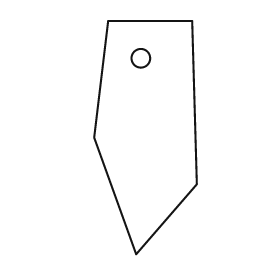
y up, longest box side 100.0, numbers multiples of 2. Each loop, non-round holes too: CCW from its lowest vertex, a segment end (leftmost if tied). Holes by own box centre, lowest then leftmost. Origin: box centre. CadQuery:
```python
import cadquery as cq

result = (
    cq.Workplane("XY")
    .moveTo(-4.0, -50.0)
    .lineTo(22.0, -20.0)
    .lineTo(20.0, 50.0)
    .lineTo(-16.0, 50.0)
    .lineTo(-22.0, 0.0)
    .close()
    .moveTo(-2.0, 34.0)
    .circle(4.0)
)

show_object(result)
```